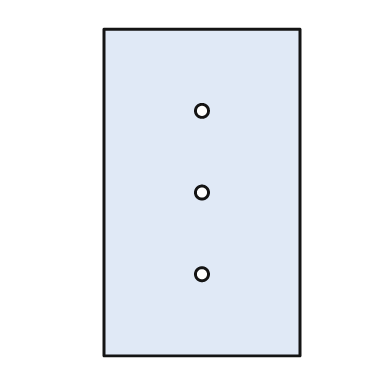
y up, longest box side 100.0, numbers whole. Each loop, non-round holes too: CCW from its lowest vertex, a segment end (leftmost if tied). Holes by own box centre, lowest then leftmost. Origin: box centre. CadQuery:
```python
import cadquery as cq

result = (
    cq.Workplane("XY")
    .moveTo(-30.0, -50.0)
    .lineTo(30.0, -50.0)
    .lineTo(30.0, 50.0)
    .lineTo(-30.0, 50.0)
    .close()
    .moveTo(0.0, -25.0)
    .circle(2.0)
    .moveTo(0.0, 0.0)
    .circle(2.0)
    .moveTo(0.0, 25.0)
    .circle(2.0)
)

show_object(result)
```